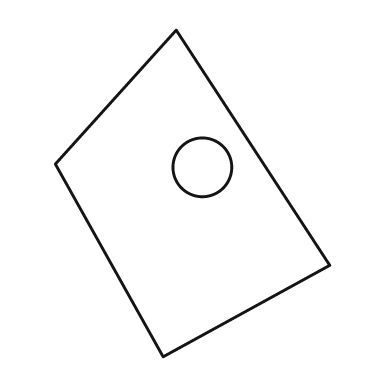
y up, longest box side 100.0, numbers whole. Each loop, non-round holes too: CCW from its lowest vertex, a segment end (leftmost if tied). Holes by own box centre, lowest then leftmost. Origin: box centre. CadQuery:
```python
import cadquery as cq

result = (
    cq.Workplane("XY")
    .moveTo(-9.0, -50.0)
    .lineTo(42.0, -22.0)
    .lineTo(-5.0, 50.0)
    .lineTo(-42.0, 9.0)
    .close()
    .moveTo(3.0, 8.0)
    .circle(9.0)
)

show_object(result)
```